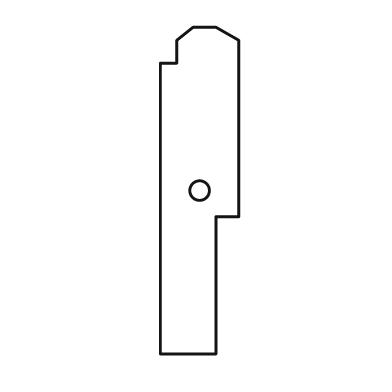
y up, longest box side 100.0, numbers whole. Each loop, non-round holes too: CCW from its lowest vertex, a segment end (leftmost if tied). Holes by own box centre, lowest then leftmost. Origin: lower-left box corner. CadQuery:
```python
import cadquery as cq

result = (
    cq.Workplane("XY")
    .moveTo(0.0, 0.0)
    .lineTo(17.0, 0.0)
    .lineTo(17.0, 42.0)
    .lineTo(24.0, 42.0)
    .lineTo(24.0, 96.0)
    .lineTo(17.0, 100.0)
    .lineTo(10.0, 100.0)
    .lineTo(5.0, 96.0)
    .lineTo(5.0, 89.0)
    .lineTo(0.0, 89.0)
    .close()
    .moveTo(12.0, 50.0)
    .circle(3.0)
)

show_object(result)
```